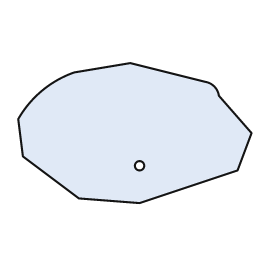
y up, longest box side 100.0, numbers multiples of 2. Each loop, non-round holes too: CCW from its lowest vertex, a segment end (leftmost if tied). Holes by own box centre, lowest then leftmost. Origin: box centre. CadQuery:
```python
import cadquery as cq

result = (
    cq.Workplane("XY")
    .moveTo(2.0, -30.0)
    .lineTo(44.0, -16.0)
    .lineTo(50.0, 0.0)
    .lineTo(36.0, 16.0)
    .threePointArc((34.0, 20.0), (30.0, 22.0))
    .lineTo(-2.0, 30.0)
    .lineTo(-26.0, 26.0)
    .threePointArc((-40.0, 18.0), (-50.0, 6.0))
    .lineTo(-48.0, -10.0)
    .lineTo(-24.0, -28.0)
    .close()
    .moveTo(2.0, -14.0)
    .circle(2.0)
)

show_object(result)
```